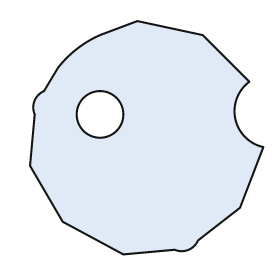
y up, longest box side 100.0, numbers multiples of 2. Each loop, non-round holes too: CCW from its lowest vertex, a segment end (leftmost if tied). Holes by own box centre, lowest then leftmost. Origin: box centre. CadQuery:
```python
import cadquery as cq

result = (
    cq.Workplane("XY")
    .moveTo(-10.0, -50.0)
    .lineTo(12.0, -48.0)
    .threePointArc((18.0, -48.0), (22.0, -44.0))
    .lineTo(40.0, -30.0)
    .lineTo(50.0, -4.0)
    .threePointArc((38.0, 8.0), (44.0, 24.0))
    .lineTo(24.0, 44.0)
    .lineTo(-4.0, 50.0)
    .lineTo(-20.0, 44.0)
    .threePointArc((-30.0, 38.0), (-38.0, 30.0))
    .lineTo(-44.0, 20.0)
    .threePointArc((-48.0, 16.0), (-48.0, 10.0))
    .lineTo(-50.0, -12.0)
    .lineTo(-36.0, -36.0)
    .close()
    .moveTo(-20.0, 10.0)
    .circle(10.0)
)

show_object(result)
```